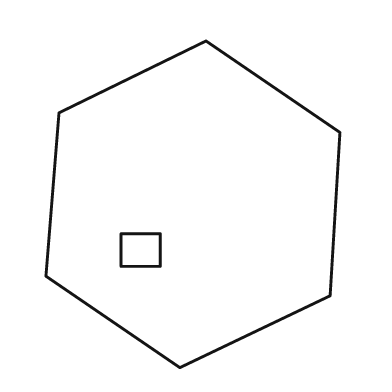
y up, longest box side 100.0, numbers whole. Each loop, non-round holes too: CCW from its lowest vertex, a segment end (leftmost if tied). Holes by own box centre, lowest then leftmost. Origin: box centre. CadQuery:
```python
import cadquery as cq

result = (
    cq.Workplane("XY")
    .moveTo(-4.0, -50.0)
    .lineTo(42.0, -28.0)
    .lineTo(45.0, 22.0)
    .lineTo(4.0, 50.0)
    .lineTo(-41.0, 28.0)
    .lineTo(-45.0, -22.0)
    .close()
    .moveTo(-22.0, -19.0)
    .lineTo(-10.0, -19.0)
    .lineTo(-10.0, -9.0)
    .lineTo(-22.0, -9.0)
    .close()
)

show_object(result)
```